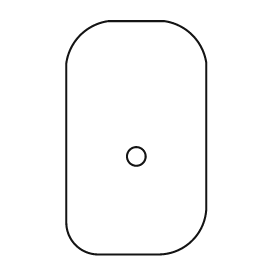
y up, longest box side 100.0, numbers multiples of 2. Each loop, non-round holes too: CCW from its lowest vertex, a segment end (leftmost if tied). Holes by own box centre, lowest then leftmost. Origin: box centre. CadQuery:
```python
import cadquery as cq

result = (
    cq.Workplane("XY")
    .moveTo(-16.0, -50.0)
    .lineTo(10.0, -50.0)
    .threePointArc((24.0, -44.0), (30.0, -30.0))
    .lineTo(30.0, 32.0)
    .threePointArc((24.0, 44.0), (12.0, 50.0))
    .lineTo(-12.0, 50.0)
    .threePointArc((-24.0, 44.0), (-30.0, 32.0))
    .lineTo(-30.0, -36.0)
    .threePointArc((-26.0, -46.0), (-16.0, -50.0))
    .close()
    .moveTo(0.0, -8.0)
    .circle(4.0)
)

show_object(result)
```